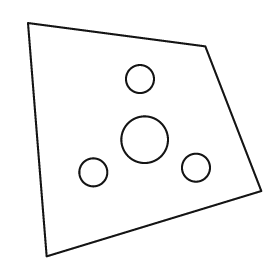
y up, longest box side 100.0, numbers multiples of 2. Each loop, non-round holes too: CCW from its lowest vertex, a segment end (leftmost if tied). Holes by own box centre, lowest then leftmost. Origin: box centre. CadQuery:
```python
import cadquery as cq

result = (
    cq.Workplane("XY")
    .moveTo(-42.0, -50.0)
    .lineTo(50.0, -22.0)
    .lineTo(26.0, 40.0)
    .lineTo(-50.0, 50.0)
    .close()
    .moveTo(-22.0, -14.0)
    .circle(6.0)
    .moveTo(22.0, -12.0)
    .circle(6.0)
    .moveTo(0.0, 0.0)
    .circle(10.0)
    .moveTo(-2.0, 26.0)
    .circle(6.0)
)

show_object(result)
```